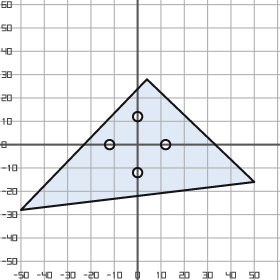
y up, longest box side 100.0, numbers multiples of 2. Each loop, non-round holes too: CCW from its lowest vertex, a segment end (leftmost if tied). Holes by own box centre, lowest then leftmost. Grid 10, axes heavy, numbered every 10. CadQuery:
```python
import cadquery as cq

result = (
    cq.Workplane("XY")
    .moveTo(-50.0, -28.0)
    .lineTo(50.0, -16.0)
    .lineTo(4.0, 28.0)
    .close()
    .moveTo(0.0, -12.0)
    .circle(2.0)
    .moveTo(-12.0, 0.0)
    .circle(2.0)
    .moveTo(12.0, 0.0)
    .circle(2.0)
    .moveTo(0.0, 12.0)
    .circle(2.0)
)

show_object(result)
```